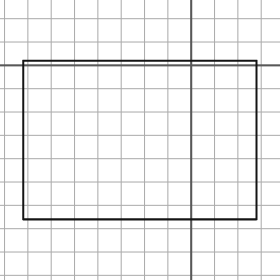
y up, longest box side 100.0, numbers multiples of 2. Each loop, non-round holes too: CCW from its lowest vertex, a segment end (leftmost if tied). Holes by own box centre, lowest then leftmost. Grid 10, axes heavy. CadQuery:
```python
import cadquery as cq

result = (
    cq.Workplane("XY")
    .moveTo(-72.0, -66.0)
    .lineTo(28.0, -66.0)
    .lineTo(28.0, 2.0)
    .lineTo(-72.0, 2.0)
    .close()
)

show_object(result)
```